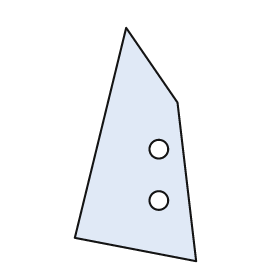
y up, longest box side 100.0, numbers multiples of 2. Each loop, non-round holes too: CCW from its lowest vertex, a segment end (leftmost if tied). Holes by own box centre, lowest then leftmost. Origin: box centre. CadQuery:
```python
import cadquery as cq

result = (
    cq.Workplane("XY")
    .moveTo(26.0, -50.0)
    .lineTo(18.0, 18.0)
    .lineTo(-4.0, 50.0)
    .lineTo(-26.0, -40.0)
    .close()
    .moveTo(10.0, -24.0)
    .circle(4.0)
    .moveTo(10.0, -2.0)
    .circle(4.0)
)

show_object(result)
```